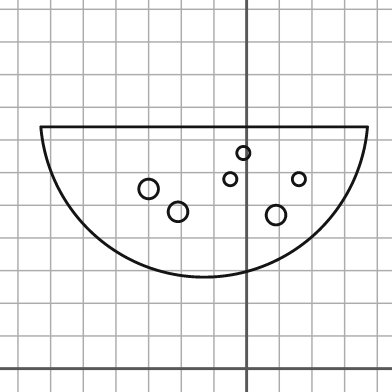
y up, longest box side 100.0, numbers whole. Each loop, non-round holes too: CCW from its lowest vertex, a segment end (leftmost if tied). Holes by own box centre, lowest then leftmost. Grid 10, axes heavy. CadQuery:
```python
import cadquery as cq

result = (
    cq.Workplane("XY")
    .moveTo(-63.0, 74.0)
    .threePointArc((-13.0, 28.0), (37.0, 74.0))
    .close()
    .moveTo(9.0, 47.0)
    .circle(3.0)
    .moveTo(-21.0, 48.0)
    .circle(3.0)
    .moveTo(-30.0, 55.0)
    .circle(3.0)
    .moveTo(-5.0, 58.0)
    .circle(2.0)
    .moveTo(16.0, 58.0)
    .circle(2.0)
    .moveTo(-1.0, 66.0)
    .circle(2.0)
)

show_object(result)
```